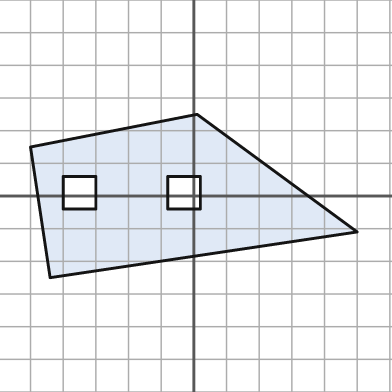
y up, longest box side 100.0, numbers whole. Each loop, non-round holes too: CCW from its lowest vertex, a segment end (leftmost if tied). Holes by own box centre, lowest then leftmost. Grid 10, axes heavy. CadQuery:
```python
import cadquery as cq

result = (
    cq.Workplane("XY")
    .moveTo(-44.0, -25.0)
    .lineTo(50.0, -11.0)
    .lineTo(1.0, 25.0)
    .lineTo(-50.0, 15.0)
    .close()
    .moveTo(-40.0, -4.0)
    .lineTo(-30.0, -4.0)
    .lineTo(-30.0, 6.0)
    .lineTo(-40.0, 6.0)
    .close()
    .moveTo(-8.0, -4.0)
    .lineTo(2.0, -4.0)
    .lineTo(2.0, 6.0)
    .lineTo(-8.0, 6.0)
    .close()
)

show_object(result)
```